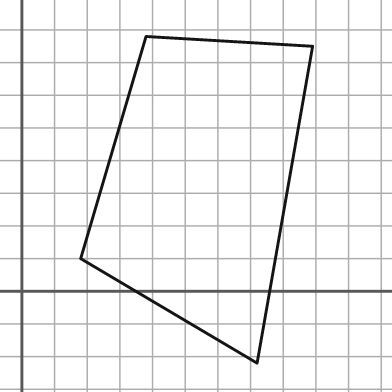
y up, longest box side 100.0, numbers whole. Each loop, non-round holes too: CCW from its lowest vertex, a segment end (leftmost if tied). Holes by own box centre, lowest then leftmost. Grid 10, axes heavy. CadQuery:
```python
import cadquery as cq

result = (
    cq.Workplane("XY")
    .moveTo(72.0, -22.0)
    .lineTo(89.0, 75.0)
    .lineTo(38.0, 78.0)
    .lineTo(18.0, 10.0)
    .close()
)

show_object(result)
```